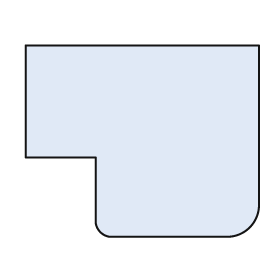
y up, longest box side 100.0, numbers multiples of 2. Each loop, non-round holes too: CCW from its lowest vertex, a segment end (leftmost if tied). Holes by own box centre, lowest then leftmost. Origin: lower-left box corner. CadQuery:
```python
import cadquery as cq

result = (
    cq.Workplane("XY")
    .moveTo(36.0, 0.0)
    .lineTo(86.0, 0.0)
    .threePointArc((96.0, 4.0), (100.0, 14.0))
    .lineTo(100.0, 82.0)
    .lineTo(0.0, 82.0)
    .lineTo(0.0, 34.0)
    .lineTo(30.0, 34.0)
    .lineTo(30.0, 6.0)
    .threePointArc((32.0, 2.0), (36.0, 0.0))
    .close()
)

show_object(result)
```